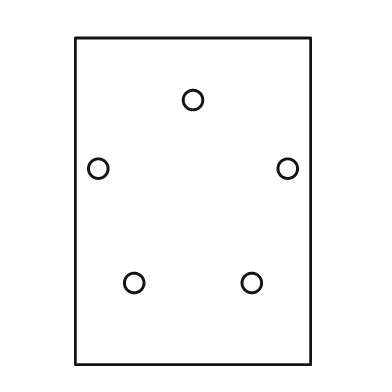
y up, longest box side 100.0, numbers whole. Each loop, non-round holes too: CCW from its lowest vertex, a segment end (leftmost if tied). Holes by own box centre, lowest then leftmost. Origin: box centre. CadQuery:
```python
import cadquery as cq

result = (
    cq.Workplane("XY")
    .moveTo(-36.0, -50.0)
    .lineTo(36.0, -50.0)
    .lineTo(36.0, 50.0)
    .lineTo(-36.0, 50.0)
    .close()
    .moveTo(-18.0, -25.0)
    .circle(3.0)
    .moveTo(18.0, -25.0)
    .circle(3.0)
    .moveTo(-29.0, 10.0)
    .circle(3.0)
    .moveTo(29.0, 10.0)
    .circle(3.0)
    .moveTo(0.0, 31.0)
    .circle(3.0)
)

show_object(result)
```